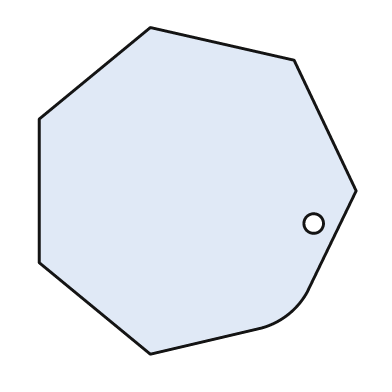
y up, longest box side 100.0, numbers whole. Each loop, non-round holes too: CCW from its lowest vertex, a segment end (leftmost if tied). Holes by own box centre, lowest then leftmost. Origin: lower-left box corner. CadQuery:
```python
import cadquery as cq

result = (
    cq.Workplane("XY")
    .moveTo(34.0, 0.0)
    .lineTo(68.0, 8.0)
    .threePointArc((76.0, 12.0), (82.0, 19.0))
    .lineTo(97.0, 50.0)
    .lineTo(78.0, 90.0)
    .lineTo(34.0, 100.0)
    .lineTo(0.0, 72.0)
    .lineTo(0.0, 28.0)
    .close()
    .moveTo(84.0, 40.0)
    .circle(3.0)
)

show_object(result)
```